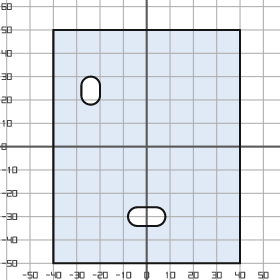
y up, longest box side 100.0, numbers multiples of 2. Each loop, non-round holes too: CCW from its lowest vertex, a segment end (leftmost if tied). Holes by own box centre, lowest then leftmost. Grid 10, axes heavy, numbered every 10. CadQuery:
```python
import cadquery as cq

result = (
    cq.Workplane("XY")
    .moveTo(-40.0, -50.0)
    .lineTo(40.0, -50.0)
    .lineTo(40.0, 50.0)
    .lineTo(-40.0, 50.0)
    .close()
    .moveTo(-4.0, -34.0)
    .lineTo(4.0, -34.0)
    .threePointArc((8.0, -30.0), (4.0, -26.0))
    .lineTo(-4.0, -26.0)
    .threePointArc((-8.0, -30.0), (-4.0, -34.0))
    .close()
    .moveTo(-28.0, 22.0)
    .threePointArc((-24.0, 18.0), (-20.0, 22.0))
    .lineTo(-20.0, 26.0)
    .threePointArc((-24.0, 30.0), (-28.0, 26.0))
    .close()
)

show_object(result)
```